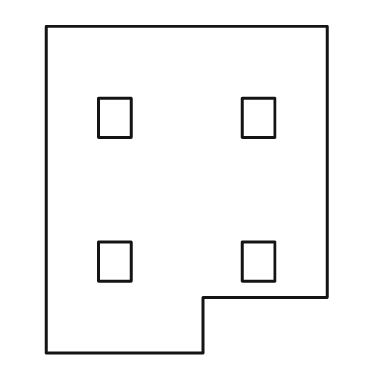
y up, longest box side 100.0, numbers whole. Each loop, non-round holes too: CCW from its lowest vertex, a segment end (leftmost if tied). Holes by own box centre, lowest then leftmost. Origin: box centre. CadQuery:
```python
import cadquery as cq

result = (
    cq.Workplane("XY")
    .moveTo(-43.0, -50.0)
    .lineTo(5.0, -50.0)
    .lineTo(5.0, -33.0)
    .lineTo(43.0, -33.0)
    .lineTo(43.0, 50.0)
    .lineTo(-43.0, 50.0)
    .close()
    .moveTo(-27.0, -28.0)
    .lineTo(-17.0, -28.0)
    .lineTo(-17.0, -16.0)
    .lineTo(-27.0, -16.0)
    .close()
    .moveTo(17.0, -28.0)
    .lineTo(27.0, -28.0)
    .lineTo(27.0, -16.0)
    .lineTo(17.0, -16.0)
    .close()
    .moveTo(-27.0, 16.0)
    .lineTo(-17.0, 16.0)
    .lineTo(-17.0, 28.0)
    .lineTo(-27.0, 28.0)
    .close()
    .moveTo(17.0, 16.0)
    .lineTo(27.0, 16.0)
    .lineTo(27.0, 28.0)
    .lineTo(17.0, 28.0)
    .close()
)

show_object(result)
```